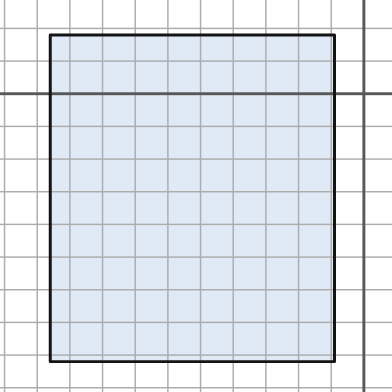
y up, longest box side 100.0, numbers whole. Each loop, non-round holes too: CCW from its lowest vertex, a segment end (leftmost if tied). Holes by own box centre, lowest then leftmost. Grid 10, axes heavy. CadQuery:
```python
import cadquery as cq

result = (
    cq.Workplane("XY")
    .moveTo(-96.0, -82.0)
    .lineTo(-9.0, -82.0)
    .lineTo(-9.0, 18.0)
    .lineTo(-96.0, 18.0)
    .close()
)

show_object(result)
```